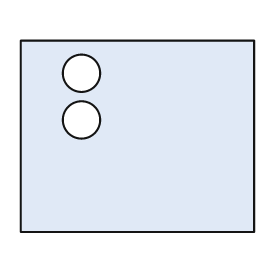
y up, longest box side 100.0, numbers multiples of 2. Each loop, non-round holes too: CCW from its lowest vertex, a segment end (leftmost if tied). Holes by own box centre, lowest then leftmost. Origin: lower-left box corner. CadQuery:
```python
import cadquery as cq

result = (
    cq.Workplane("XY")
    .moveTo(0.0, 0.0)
    .lineTo(100.0, 0.0)
    .lineTo(100.0, 82.0)
    .lineTo(0.0, 82.0)
    .close()
    .moveTo(26.0, 48.0)
    .circle(8.0)
    .moveTo(26.0, 68.0)
    .circle(8.0)
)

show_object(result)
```